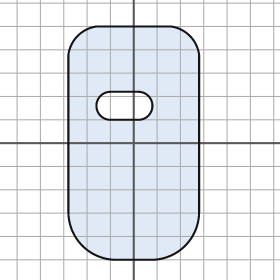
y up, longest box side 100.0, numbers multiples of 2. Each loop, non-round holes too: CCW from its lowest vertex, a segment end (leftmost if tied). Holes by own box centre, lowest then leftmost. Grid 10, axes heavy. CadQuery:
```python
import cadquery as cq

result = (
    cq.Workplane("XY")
    .moveTo(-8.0, -50.0)
    .lineTo(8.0, -50.0)
    .threePointArc((22.0, -44.0), (28.0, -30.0))
    .lineTo(28.0, 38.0)
    .threePointArc((24.0, 46.0), (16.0, 50.0))
    .lineTo(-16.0, 50.0)
    .threePointArc((-24.0, 46.0), (-28.0, 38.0))
    .lineTo(-28.0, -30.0)
    .threePointArc((-22.0, -44.0), (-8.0, -50.0))
    .close()
    .moveTo(-10.0, 10.0)
    .lineTo(2.0, 10.0)
    .threePointArc((8.0, 16.0), (2.0, 22.0))
    .lineTo(-10.0, 22.0)
    .threePointArc((-16.0, 16.0), (-10.0, 10.0))
    .close()
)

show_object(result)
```